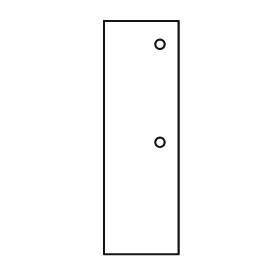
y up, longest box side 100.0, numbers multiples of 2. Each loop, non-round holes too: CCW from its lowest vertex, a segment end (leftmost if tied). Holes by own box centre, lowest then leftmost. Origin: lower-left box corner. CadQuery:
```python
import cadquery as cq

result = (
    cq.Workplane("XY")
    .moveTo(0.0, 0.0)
    .lineTo(32.0, 0.0)
    .lineTo(32.0, 100.0)
    .lineTo(0.0, 100.0)
    .close()
    .moveTo(24.0, 48.0)
    .circle(2.0)
    .moveTo(24.0, 90.0)
    .circle(2.0)
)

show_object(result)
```